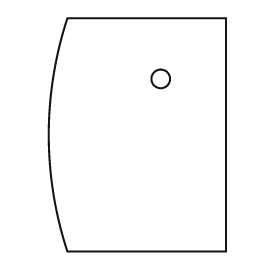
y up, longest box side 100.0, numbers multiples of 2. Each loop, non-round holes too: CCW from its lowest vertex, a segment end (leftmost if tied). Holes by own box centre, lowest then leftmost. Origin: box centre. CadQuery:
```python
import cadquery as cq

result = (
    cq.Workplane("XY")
    .moveTo(-30.0, -50.0)
    .lineTo(38.0, -50.0)
    .lineTo(38.0, 50.0)
    .lineTo(-30.0, 50.0)
    .threePointArc((-38.0, 0.0), (-30.0, -50.0))
    .close()
    .moveTo(10.0, 24.0)
    .circle(4.0)
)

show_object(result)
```